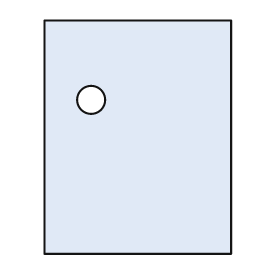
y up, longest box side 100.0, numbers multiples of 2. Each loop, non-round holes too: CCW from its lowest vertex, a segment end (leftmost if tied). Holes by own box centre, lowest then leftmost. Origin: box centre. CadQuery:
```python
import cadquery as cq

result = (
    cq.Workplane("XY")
    .moveTo(-40.0, -50.0)
    .lineTo(40.0, -50.0)
    .lineTo(40.0, 50.0)
    .lineTo(-40.0, 50.0)
    .close()
    .moveTo(-20.0, 16.0)
    .circle(6.0)
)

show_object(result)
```